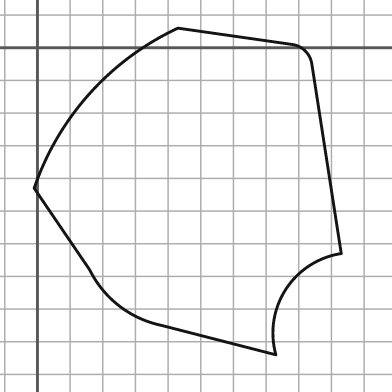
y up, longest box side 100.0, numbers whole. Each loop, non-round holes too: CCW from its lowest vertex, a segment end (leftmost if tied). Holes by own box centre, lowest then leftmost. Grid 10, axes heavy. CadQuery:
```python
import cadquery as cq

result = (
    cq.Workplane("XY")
    .moveTo(73.0, -94.0)
    .threePointArc((76.0, -74.0), (93.0, -63.0))
    .lineTo(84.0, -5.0)
    .threePointArc((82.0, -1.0), (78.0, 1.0))
    .lineTo(43.0, 6.0)
    .threePointArc((16.0, -14.0), (-1.0, -43.0))
    .lineTo(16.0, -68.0)
    .threePointArc((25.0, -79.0), (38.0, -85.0))
    .close()
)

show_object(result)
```